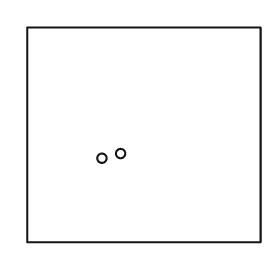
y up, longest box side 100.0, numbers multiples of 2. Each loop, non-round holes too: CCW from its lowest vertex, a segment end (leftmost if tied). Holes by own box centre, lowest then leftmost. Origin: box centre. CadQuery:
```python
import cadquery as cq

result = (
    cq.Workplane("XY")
    .moveTo(-50.0, -46.0)
    .lineTo(50.0, -46.0)
    .lineTo(50.0, 46.0)
    .lineTo(-50.0, 46.0)
    .close()
    .moveTo(-18.0, -10.0)
    .circle(2.0)
    .moveTo(-10.0, -8.0)
    .circle(2.0)
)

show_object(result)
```